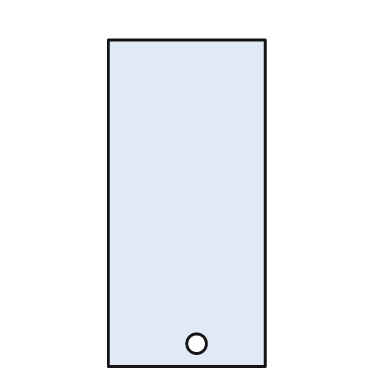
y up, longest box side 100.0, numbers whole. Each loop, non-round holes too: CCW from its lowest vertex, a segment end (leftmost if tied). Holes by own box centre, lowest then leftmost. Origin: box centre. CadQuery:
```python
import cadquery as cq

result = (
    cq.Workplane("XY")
    .moveTo(-24.0, -50.0)
    .lineTo(24.0, -50.0)
    .lineTo(24.0, 50.0)
    .lineTo(-24.0, 50.0)
    .close()
    .moveTo(3.0, -43.0)
    .circle(3.0)
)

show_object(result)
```